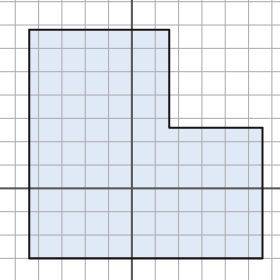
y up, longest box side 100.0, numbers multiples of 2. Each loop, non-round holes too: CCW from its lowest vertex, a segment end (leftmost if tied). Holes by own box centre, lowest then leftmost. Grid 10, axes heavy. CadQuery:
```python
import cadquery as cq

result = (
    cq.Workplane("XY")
    .moveTo(-44.0, -30.0)
    .lineTo(56.0, -30.0)
    .lineTo(56.0, 26.0)
    .lineTo(16.0, 26.0)
    .lineTo(16.0, 68.0)
    .lineTo(-44.0, 68.0)
    .close()
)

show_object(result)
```